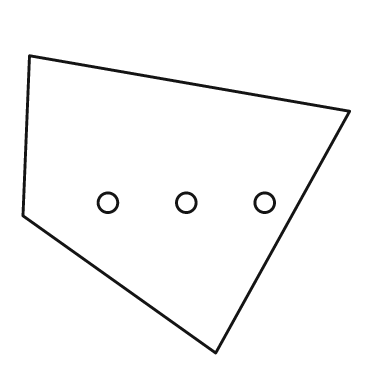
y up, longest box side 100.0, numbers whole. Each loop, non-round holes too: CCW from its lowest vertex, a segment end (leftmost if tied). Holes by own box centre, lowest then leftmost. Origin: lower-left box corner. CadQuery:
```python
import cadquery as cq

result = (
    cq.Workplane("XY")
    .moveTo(59.0, 0.0)
    .lineTo(100.0, 74.0)
    .lineTo(2.0, 91.0)
    .lineTo(0.0, 42.0)
    .close()
    .moveTo(26.0, 46.0)
    .circle(3.0)
    .moveTo(50.0, 46.0)
    .circle(3.0)
    .moveTo(74.0, 46.0)
    .circle(3.0)
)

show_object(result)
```